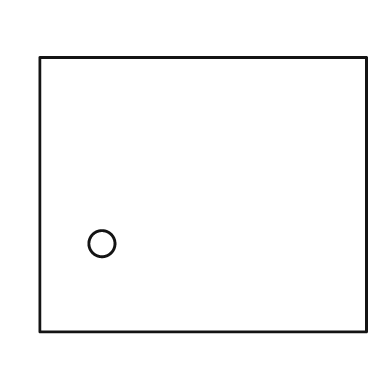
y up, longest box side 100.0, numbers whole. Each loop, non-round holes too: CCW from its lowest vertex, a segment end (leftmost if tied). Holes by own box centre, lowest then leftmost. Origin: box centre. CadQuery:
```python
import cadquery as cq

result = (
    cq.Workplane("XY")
    .moveTo(-50.0, -42.0)
    .lineTo(50.0, -42.0)
    .lineTo(50.0, 42.0)
    .lineTo(-50.0, 42.0)
    .close()
    .moveTo(-31.0, -15.0)
    .circle(4.0)
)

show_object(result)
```